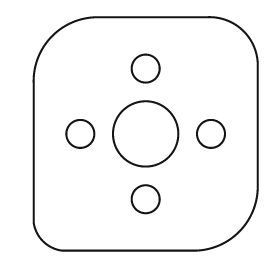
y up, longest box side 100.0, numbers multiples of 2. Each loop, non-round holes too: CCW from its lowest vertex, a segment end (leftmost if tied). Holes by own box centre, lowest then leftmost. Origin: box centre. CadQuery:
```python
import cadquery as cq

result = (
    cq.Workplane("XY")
    .moveTo(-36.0, -50.0)
    .lineTo(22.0, -50.0)
    .threePointArc((40.0, -42.0), (48.0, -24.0))
    .lineTo(48.0, 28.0)
    .threePointArc((42.0, 44.0), (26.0, 50.0))
    .lineTo(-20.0, 50.0)
    .threePointArc((-40.0, 42.0), (-48.0, 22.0))
    .lineTo(-48.0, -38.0)
    .threePointArc((-44.0, -46.0), (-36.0, -50.0))
    .close()
    .moveTo(0.0, -28.0)
    .circle(6.0)
    .moveTo(-28.0, 0.0)
    .circle(6.0)
    .moveTo(0.0, 0.0)
    .circle(14.0)
    .moveTo(28.0, 0.0)
    .circle(6.0)
    .moveTo(0.0, 28.0)
    .circle(6.0)
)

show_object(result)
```